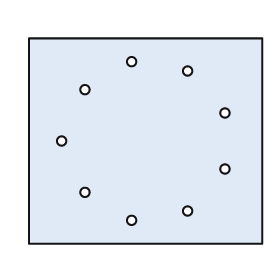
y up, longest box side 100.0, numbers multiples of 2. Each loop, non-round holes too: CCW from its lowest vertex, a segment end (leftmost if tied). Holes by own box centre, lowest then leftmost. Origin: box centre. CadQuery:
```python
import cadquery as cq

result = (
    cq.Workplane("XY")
    .moveTo(-50.0, -44.0)
    .lineTo(50.0, -44.0)
    .lineTo(50.0, 44.0)
    .lineTo(-50.0, 44.0)
    .close()
    .moveTo(-6.0, -34.0)
    .circle(2.0)
    .moveTo(18.0, -30.0)
    .circle(2.0)
    .moveTo(-26.0, -22.0)
    .circle(2.0)
    .moveTo(34.0, -12.0)
    .circle(2.0)
    .moveTo(-36.0, 0.0)
    .circle(2.0)
    .moveTo(34.0, 12.0)
    .circle(2.0)
    .moveTo(-26.0, 22.0)
    .circle(2.0)
    .moveTo(18.0, 30.0)
    .circle(2.0)
    .moveTo(-6.0, 34.0)
    .circle(2.0)
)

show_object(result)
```